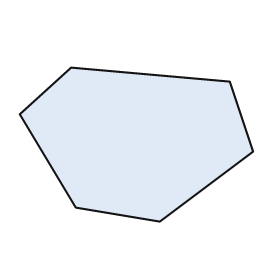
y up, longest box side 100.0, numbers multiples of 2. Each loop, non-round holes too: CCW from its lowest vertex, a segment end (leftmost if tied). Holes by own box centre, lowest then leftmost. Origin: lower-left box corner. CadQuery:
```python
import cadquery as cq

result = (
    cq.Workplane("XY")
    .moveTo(60.0, 0.0)
    .lineTo(100.0, 30.0)
    .lineTo(90.0, 60.0)
    .lineTo(22.0, 66.0)
    .lineTo(0.0, 46.0)
    .lineTo(24.0, 6.0)
    .close()
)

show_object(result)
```